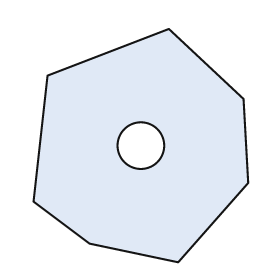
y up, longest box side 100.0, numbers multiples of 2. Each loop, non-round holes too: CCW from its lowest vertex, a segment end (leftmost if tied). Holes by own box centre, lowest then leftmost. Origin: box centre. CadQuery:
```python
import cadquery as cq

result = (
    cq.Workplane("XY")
    .moveTo(16.0, -50.0)
    .lineTo(46.0, -16.0)
    .lineTo(44.0, 20.0)
    .lineTo(12.0, 50.0)
    .lineTo(-40.0, 30.0)
    .lineTo(-46.0, -24.0)
    .lineTo(-22.0, -42.0)
    .close()
    .moveTo(0.0, 0.0)
    .circle(10.0)
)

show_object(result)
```